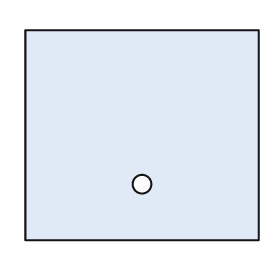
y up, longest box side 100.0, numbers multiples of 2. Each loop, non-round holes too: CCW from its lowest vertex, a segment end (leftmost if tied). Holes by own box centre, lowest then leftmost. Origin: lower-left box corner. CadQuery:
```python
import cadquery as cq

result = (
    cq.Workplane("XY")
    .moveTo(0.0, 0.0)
    .lineTo(100.0, 0.0)
    .lineTo(100.0, 90.0)
    .lineTo(0.0, 90.0)
    .close()
    .moveTo(50.0, 24.0)
    .circle(4.0)
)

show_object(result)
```